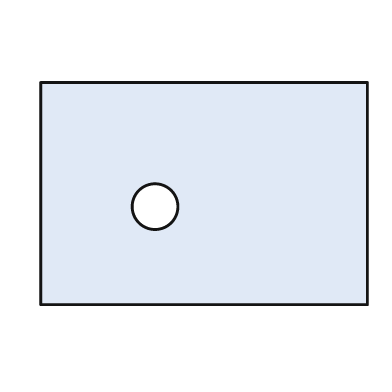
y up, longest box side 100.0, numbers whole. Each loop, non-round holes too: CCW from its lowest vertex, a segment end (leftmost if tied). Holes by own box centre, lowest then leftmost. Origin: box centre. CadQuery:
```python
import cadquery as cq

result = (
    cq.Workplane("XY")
    .moveTo(-50.0, -34.0)
    .lineTo(50.0, -34.0)
    .lineTo(50.0, 34.0)
    .lineTo(-50.0, 34.0)
    .close()
    .moveTo(-15.0, -4.0)
    .circle(7.0)
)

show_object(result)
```